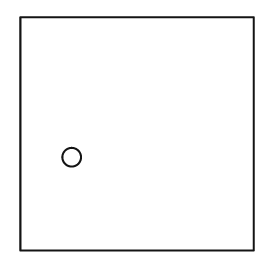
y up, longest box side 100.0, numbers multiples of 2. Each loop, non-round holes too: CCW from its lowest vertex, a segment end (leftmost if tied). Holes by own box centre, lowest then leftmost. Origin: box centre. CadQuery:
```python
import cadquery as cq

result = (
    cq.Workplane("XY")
    .moveTo(-50.0, -50.0)
    .lineTo(50.0, -50.0)
    .lineTo(50.0, 50.0)
    .lineTo(-50.0, 50.0)
    .close()
    .moveTo(-28.0, -10.0)
    .circle(4.0)
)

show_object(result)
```